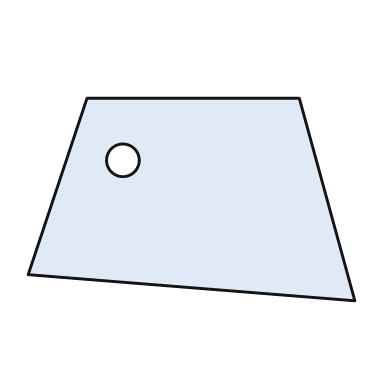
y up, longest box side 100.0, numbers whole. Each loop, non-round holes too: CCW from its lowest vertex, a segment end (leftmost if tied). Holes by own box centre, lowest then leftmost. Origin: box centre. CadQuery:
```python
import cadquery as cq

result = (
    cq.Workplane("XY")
    .moveTo(50.0, -31.0)
    .lineTo(33.0, 31.0)
    .lineTo(-32.0, 31.0)
    .lineTo(-50.0, -23.0)
    .close()
    .moveTo(-21.0, 12.0)
    .circle(5.0)
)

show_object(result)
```